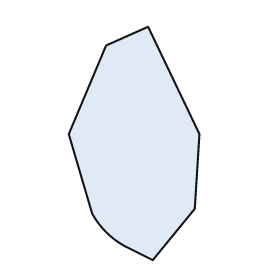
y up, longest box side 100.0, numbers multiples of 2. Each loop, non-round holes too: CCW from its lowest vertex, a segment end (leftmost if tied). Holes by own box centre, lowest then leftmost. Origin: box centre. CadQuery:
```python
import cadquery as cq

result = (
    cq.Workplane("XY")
    .moveTo(8.0, -50.0)
    .lineTo(26.0, -28.0)
    .lineTo(28.0, 4.0)
    .lineTo(6.0, 50.0)
    .lineTo(-12.0, 42.0)
    .lineTo(-28.0, 4.0)
    .lineTo(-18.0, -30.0)
    .threePointArc((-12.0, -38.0), (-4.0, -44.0))
    .close()
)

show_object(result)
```